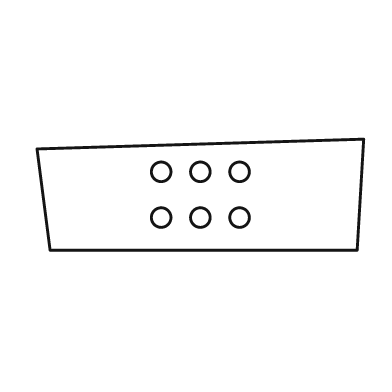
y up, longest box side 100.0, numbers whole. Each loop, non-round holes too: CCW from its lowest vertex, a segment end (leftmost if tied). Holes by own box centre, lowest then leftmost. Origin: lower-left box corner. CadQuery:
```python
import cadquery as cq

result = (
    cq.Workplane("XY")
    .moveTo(4.0, 0.0)
    .lineTo(98.0, 0.0)
    .lineTo(100.0, 34.0)
    .lineTo(0.0, 31.0)
    .close()
    .moveTo(38.0, 10.0)
    .circle(3.0)
    .moveTo(50.0, 10.0)
    .circle(3.0)
    .moveTo(62.0, 10.0)
    .circle(3.0)
    .moveTo(38.0, 24.0)
    .circle(3.0)
    .moveTo(50.0, 24.0)
    .circle(3.0)
    .moveTo(62.0, 24.0)
    .circle(3.0)
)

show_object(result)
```